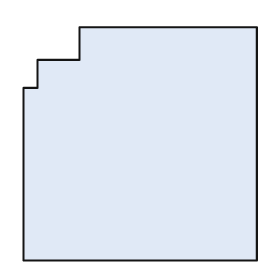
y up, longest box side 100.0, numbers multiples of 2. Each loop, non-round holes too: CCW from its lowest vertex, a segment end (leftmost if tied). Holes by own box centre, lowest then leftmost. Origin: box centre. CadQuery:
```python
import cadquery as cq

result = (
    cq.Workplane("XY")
    .moveTo(-50.0, -50.0)
    .lineTo(50.0, -50.0)
    .lineTo(50.0, 50.0)
    .lineTo(-26.0, 50.0)
    .lineTo(-26.0, 36.0)
    .lineTo(-44.0, 36.0)
    .lineTo(-44.0, 24.0)
    .lineTo(-50.0, 24.0)
    .close()
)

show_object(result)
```